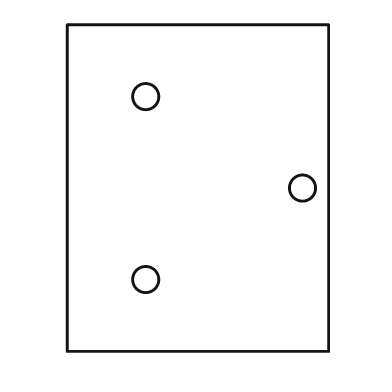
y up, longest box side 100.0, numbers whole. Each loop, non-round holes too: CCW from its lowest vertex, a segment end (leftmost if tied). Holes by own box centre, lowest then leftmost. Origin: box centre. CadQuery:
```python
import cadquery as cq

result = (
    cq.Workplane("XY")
    .moveTo(-40.0, -50.0)
    .lineTo(40.0, -50.0)
    .lineTo(40.0, 50.0)
    .lineTo(-40.0, 50.0)
    .close()
    .moveTo(-16.0, -28.0)
    .circle(4.0)
    .moveTo(32.0, 0.0)
    .circle(4.0)
    .moveTo(-16.0, 28.0)
    .circle(4.0)
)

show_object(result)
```